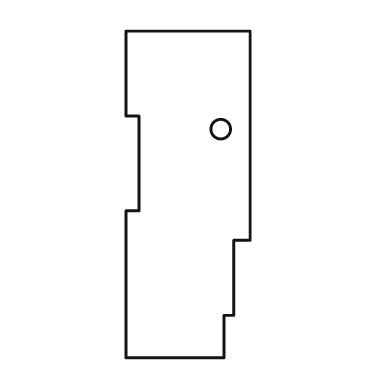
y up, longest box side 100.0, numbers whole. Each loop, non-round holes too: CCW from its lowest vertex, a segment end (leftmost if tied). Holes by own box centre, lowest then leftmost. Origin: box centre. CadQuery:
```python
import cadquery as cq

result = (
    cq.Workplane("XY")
    .moveTo(-19.0, -50.0)
    .lineTo(11.0, -50.0)
    .lineTo(11.0, -37.0)
    .lineTo(14.0, -37.0)
    .lineTo(14.0, -14.0)
    .lineTo(19.0, -14.0)
    .lineTo(19.0, 50.0)
    .lineTo(-19.0, 50.0)
    .lineTo(-19.0, 24.0)
    .lineTo(-15.0, 24.0)
    .lineTo(-15.0, -5.0)
    .lineTo(-19.0, -5.0)
    .close()
    .moveTo(10.0, 20.0)
    .circle(3.0)
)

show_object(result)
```